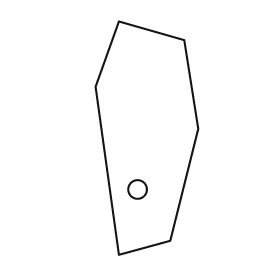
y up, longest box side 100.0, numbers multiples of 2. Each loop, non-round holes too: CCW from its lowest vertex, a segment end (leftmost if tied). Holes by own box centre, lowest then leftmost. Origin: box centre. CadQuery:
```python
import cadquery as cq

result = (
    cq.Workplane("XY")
    .moveTo(-12.0, -50.0)
    .lineTo(10.0, -44.0)
    .lineTo(22.0, 4.0)
    .lineTo(16.0, 42.0)
    .lineTo(-12.0, 50.0)
    .lineTo(-22.0, 22.0)
    .close()
    .moveTo(-4.0, -22.0)
    .circle(4.0)
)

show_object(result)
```